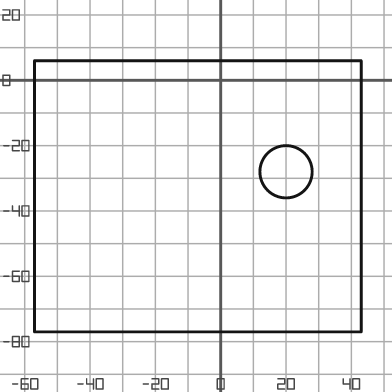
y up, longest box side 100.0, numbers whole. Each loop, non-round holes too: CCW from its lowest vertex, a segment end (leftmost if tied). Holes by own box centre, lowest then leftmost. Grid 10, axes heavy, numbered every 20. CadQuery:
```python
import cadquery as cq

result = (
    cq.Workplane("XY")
    .moveTo(-57.0, -77.0)
    .lineTo(43.0, -77.0)
    .lineTo(43.0, 6.0)
    .lineTo(-57.0, 6.0)
    .close()
    .moveTo(20.0, -28.0)
    .circle(8.0)
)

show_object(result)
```